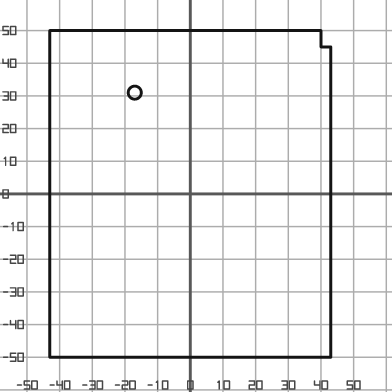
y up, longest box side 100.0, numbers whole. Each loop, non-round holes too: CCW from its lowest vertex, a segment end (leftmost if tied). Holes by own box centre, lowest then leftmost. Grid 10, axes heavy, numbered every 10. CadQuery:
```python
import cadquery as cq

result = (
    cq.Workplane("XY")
    .moveTo(-43.0, -50.0)
    .lineTo(43.0, -50.0)
    .lineTo(43.0, 45.0)
    .lineTo(40.0, 45.0)
    .lineTo(40.0, 50.0)
    .lineTo(-43.0, 50.0)
    .close()
    .moveTo(-17.0, 31.0)
    .circle(2.0)
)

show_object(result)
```